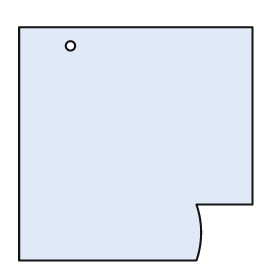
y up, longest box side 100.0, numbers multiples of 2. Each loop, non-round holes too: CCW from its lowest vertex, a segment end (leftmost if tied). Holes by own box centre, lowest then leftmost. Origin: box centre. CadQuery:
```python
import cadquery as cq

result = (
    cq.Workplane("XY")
    .moveTo(-50.0, -50.0)
    .lineTo(26.0, -50.0)
    .threePointArc((28.0, -38.0), (26.0, -26.0))
    .lineTo(50.0, -26.0)
    .lineTo(50.0, 50.0)
    .lineTo(-50.0, 50.0)
    .close()
    .moveTo(-28.0, 42.0)
    .circle(2.0)
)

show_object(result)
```